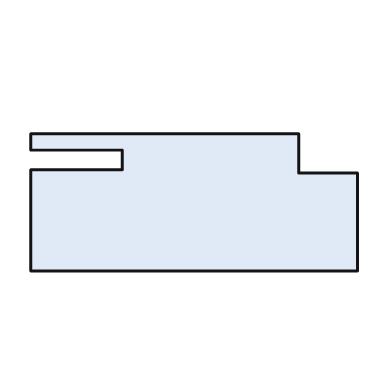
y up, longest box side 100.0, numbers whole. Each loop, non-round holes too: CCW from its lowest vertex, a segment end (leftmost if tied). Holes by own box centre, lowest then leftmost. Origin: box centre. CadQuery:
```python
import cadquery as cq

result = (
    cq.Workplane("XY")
    .moveTo(-50.0, -21.0)
    .lineTo(50.0, -21.0)
    .lineTo(50.0, 9.0)
    .lineTo(32.0, 9.0)
    .lineTo(32.0, 21.0)
    .lineTo(-50.0, 21.0)
    .lineTo(-50.0, 16.0)
    .lineTo(-22.0, 16.0)
    .lineTo(-22.0, 10.0)
    .lineTo(-50.0, 10.0)
    .close()
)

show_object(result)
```